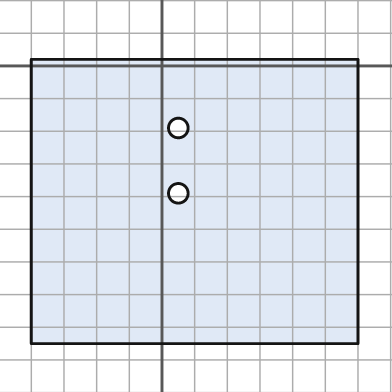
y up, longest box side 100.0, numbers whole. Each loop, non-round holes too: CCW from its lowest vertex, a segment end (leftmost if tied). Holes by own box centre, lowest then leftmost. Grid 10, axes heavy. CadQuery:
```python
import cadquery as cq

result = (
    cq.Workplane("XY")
    .moveTo(-40.0, -85.0)
    .lineTo(60.0, -85.0)
    .lineTo(60.0, 2.0)
    .lineTo(-40.0, 2.0)
    .close()
    .moveTo(5.0, -39.0)
    .circle(3.0)
    .moveTo(5.0, -19.0)
    .circle(3.0)
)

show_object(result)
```